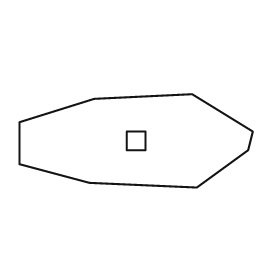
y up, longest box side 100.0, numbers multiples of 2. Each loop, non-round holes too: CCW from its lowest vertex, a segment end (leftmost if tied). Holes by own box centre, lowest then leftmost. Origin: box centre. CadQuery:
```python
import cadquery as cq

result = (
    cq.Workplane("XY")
    .moveTo(26.0, -20.0)
    .lineTo(48.0, -4.0)
    .lineTo(50.0, 4.0)
    .lineTo(24.0, 20.0)
    .lineTo(-18.0, 18.0)
    .lineTo(-50.0, 8.0)
    .lineTo(-50.0, -10.0)
    .lineTo(-20.0, -18.0)
    .close()
    .moveTo(-4.0, -4.0)
    .lineTo(4.0, -4.0)
    .lineTo(4.0, 4.0)
    .lineTo(-4.0, 4.0)
    .close()
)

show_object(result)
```